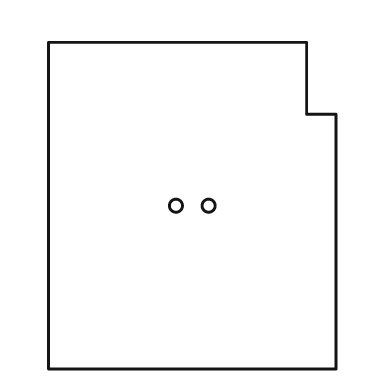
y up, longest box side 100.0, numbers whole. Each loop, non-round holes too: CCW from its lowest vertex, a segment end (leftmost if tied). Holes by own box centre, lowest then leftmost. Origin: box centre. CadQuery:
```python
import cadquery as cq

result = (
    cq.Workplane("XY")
    .moveTo(-44.0, -50.0)
    .lineTo(44.0, -50.0)
    .lineTo(44.0, 28.0)
    .lineTo(35.0, 28.0)
    .lineTo(35.0, 50.0)
    .lineTo(-44.0, 50.0)
    .close()
    .moveTo(-5.0, 0.0)
    .circle(2.0)
    .moveTo(5.0, 0.0)
    .circle(2.0)
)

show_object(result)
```